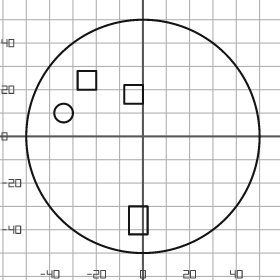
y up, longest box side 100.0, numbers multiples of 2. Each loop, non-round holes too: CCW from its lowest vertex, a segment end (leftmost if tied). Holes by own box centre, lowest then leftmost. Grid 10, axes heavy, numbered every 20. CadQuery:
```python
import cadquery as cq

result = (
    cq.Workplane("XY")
    .moveTo(0.0, 0.0)
    .circle(50.0)
    .moveTo(-6.0, -42.0)
    .lineTo(2.0, -42.0)
    .lineTo(2.0, -30.0)
    .lineTo(-6.0, -30.0)
    .close()
    .moveTo(-34.0, 10.0)
    .circle(4.0)
    .moveTo(-8.0, 14.0)
    .lineTo(0.0, 14.0)
    .lineTo(0.0, 22.0)
    .lineTo(-8.0, 22.0)
    .close()
    .moveTo(-28.0, 20.0)
    .lineTo(-20.0, 20.0)
    .lineTo(-20.0, 28.0)
    .lineTo(-28.0, 28.0)
    .close()
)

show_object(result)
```